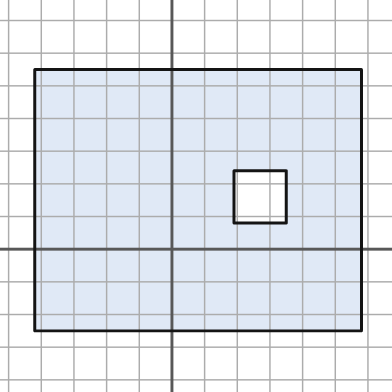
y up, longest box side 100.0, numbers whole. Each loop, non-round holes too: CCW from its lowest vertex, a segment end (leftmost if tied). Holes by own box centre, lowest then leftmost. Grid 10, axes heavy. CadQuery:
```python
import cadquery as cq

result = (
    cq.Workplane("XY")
    .moveTo(-42.0, -25.0)
    .lineTo(58.0, -25.0)
    .lineTo(58.0, 55.0)
    .lineTo(-42.0, 55.0)
    .close()
    .moveTo(19.0, 8.0)
    .lineTo(35.0, 8.0)
    .lineTo(35.0, 24.0)
    .lineTo(19.0, 24.0)
    .close()
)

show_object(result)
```